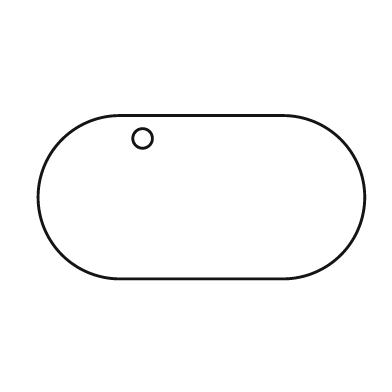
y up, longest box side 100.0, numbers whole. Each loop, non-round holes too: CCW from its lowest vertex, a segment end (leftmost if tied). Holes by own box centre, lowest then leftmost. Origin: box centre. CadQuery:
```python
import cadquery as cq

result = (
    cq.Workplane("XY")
    .moveTo(-25.0, -25.0)
    .lineTo(25.0, -25.0)
    .threePointArc((50.0, 0.0), (25.0, 25.0))
    .lineTo(-25.0, 25.0)
    .threePointArc((-50.0, 0.0), (-25.0, -25.0))
    .close()
    .moveTo(-18.0, 18.0)
    .circle(3.0)
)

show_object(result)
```